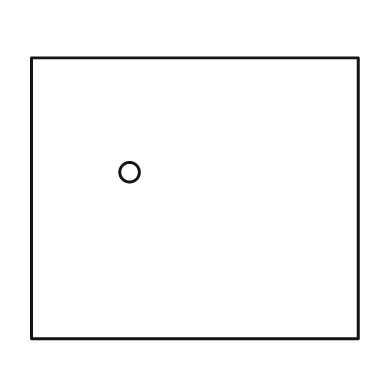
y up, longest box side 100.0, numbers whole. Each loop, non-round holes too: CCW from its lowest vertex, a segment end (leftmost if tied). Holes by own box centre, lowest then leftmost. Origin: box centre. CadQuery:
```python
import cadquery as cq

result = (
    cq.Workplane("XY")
    .moveTo(-50.0, -43.0)
    .lineTo(50.0, -43.0)
    .lineTo(50.0, 43.0)
    .lineTo(-50.0, 43.0)
    .close()
    .moveTo(-20.0, 8.0)
    .circle(3.0)
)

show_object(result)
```